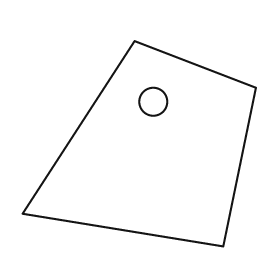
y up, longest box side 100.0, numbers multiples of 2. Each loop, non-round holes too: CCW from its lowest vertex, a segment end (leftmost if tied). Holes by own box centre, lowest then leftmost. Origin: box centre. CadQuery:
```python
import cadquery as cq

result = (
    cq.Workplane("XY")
    .moveTo(36.0, -44.0)
    .lineTo(50.0, 24.0)
    .lineTo(-2.0, 44.0)
    .lineTo(-50.0, -30.0)
    .close()
    .moveTo(6.0, 18.0)
    .circle(6.0)
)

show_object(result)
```